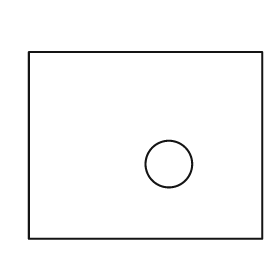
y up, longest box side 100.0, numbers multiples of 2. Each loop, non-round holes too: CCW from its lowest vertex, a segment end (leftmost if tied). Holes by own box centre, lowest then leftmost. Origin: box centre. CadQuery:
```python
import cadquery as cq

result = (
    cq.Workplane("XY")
    .moveTo(-50.0, -40.0)
    .lineTo(50.0, -40.0)
    .lineTo(50.0, 40.0)
    .lineTo(-50.0, 40.0)
    .close()
    .moveTo(10.0, -8.0)
    .circle(10.0)
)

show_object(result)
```